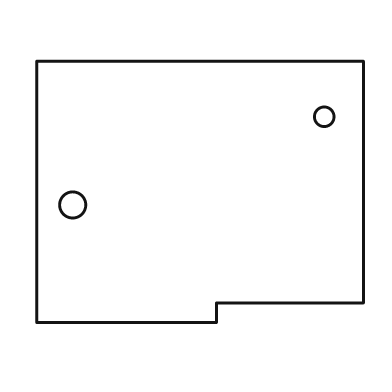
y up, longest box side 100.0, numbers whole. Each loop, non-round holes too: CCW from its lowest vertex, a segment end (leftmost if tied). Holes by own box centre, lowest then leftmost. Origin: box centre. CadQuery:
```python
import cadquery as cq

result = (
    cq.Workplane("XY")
    .moveTo(-50.0, -40.0)
    .lineTo(5.0, -40.0)
    .lineTo(5.0, -34.0)
    .lineTo(50.0, -34.0)
    .lineTo(50.0, 40.0)
    .lineTo(-50.0, 40.0)
    .close()
    .moveTo(-39.0, -4.0)
    .circle(4.0)
    .moveTo(38.0, 23.0)
    .circle(3.0)
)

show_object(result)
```